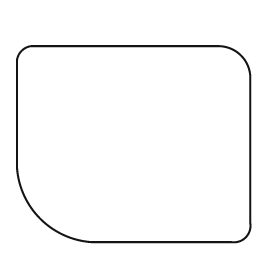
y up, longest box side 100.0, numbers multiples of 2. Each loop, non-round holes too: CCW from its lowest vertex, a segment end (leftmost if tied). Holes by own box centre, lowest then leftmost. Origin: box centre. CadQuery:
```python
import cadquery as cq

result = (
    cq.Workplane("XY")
    .moveTo(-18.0, -42.0)
    .lineTo(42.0, -42.0)
    .threePointArc((48.0, -40.0), (50.0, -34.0))
    .lineTo(50.0, 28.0)
    .threePointArc((46.0, 38.0), (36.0, 42.0))
    .lineTo(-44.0, 42.0)
    .threePointArc((-48.0, 40.0), (-50.0, 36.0))
    .lineTo(-50.0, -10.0)
    .threePointArc((-40.0, -32.0), (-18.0, -42.0))
    .close()
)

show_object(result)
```